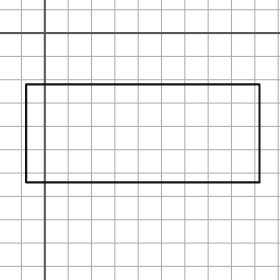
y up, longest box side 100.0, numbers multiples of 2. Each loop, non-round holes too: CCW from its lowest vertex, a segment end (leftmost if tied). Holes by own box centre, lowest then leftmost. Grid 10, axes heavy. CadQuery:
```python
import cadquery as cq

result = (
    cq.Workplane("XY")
    .moveTo(-8.0, -64.0)
    .lineTo(92.0, -64.0)
    .lineTo(92.0, -22.0)
    .lineTo(-8.0, -22.0)
    .close()
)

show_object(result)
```